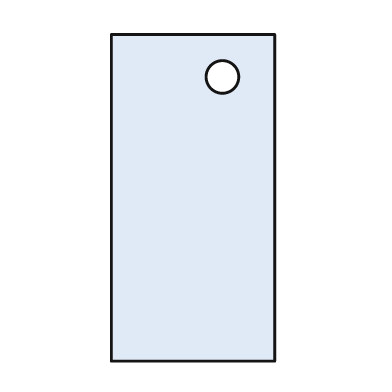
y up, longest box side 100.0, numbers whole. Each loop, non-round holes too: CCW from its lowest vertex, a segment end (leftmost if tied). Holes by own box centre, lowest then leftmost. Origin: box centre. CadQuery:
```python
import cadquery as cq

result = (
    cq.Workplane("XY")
    .moveTo(-25.0, -50.0)
    .lineTo(25.0, -50.0)
    .lineTo(25.0, 50.0)
    .lineTo(-25.0, 50.0)
    .close()
    .moveTo(9.0, 37.0)
    .circle(5.0)
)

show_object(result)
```